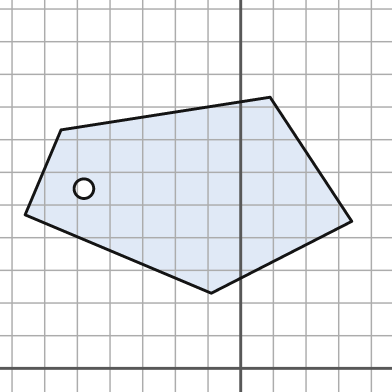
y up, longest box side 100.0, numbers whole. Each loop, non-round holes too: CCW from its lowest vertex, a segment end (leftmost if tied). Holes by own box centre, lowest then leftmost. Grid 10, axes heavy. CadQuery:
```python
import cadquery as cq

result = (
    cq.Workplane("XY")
    .moveTo(-9.0, 23.0)
    .lineTo(34.0, 45.0)
    .lineTo(9.0, 83.0)
    .lineTo(-55.0, 73.0)
    .lineTo(-66.0, 47.0)
    .close()
    .moveTo(-48.0, 55.0)
    .circle(3.0)
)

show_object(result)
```